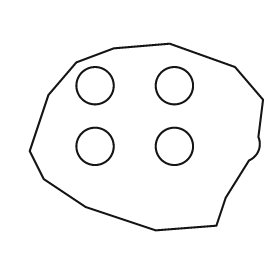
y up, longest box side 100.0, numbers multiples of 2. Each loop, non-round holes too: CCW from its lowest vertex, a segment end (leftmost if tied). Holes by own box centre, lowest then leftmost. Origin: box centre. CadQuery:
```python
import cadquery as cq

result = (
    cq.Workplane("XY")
    .moveTo(4.0, -40.0)
    .lineTo(30.0, -38.0)
    .lineTo(34.0, -26.0)
    .lineTo(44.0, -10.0)
    .threePointArc((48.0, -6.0), (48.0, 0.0))
    .lineTo(50.0, 16.0)
    .lineTo(38.0, 30.0)
    .lineTo(10.0, 40.0)
    .lineTo(-14.0, 38.0)
    .lineTo(-30.0, 32.0)
    .lineTo(-42.0, 18.0)
    .lineTo(-50.0, -6.0)
    .lineTo(-44.0, -18.0)
    .lineTo(-26.0, -30.0)
    .close()
    .moveTo(-22.0, -4.0)
    .circle(8.0)
    .moveTo(12.0, -4.0)
    .circle(8.0)
    .moveTo(-22.0, 22.0)
    .circle(8.0)
    .moveTo(12.0, 22.0)
    .circle(8.0)
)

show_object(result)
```